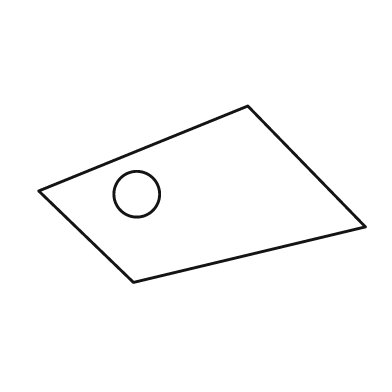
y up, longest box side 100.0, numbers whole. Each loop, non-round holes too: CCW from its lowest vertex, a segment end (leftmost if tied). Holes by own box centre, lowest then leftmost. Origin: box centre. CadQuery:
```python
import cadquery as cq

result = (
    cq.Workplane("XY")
    .moveTo(-21.0, -27.0)
    .lineTo(50.0, -10.0)
    .lineTo(14.0, 27.0)
    .lineTo(-50.0, 1.0)
    .close()
    .moveTo(-20.0, 0.0)
    .circle(7.0)
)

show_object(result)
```